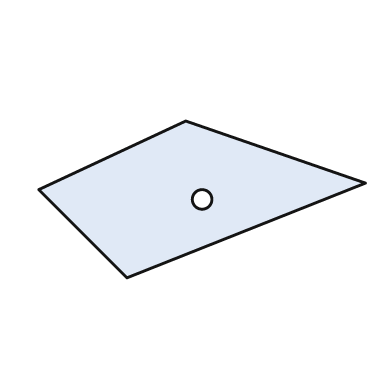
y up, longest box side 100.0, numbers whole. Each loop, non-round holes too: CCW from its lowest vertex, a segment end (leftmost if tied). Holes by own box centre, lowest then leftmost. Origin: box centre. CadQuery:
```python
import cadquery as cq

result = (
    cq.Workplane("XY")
    .moveTo(-23.0, -24.0)
    .lineTo(50.0, 5.0)
    .lineTo(-5.0, 24.0)
    .lineTo(-50.0, 3.0)
    .close()
    .moveTo(0.0, 0.0)
    .circle(3.0)
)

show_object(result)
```